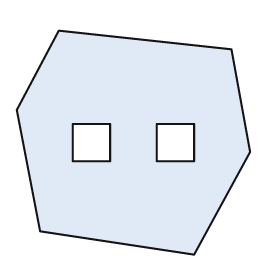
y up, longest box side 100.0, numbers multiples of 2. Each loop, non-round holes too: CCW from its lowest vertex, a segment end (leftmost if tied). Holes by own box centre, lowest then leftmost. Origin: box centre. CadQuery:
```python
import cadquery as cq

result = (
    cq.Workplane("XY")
    .moveTo(26.0, -48.0)
    .lineTo(50.0, -4.0)
    .lineTo(42.0, 40.0)
    .lineTo(-32.0, 48.0)
    .lineTo(-50.0, 14.0)
    .lineTo(-40.0, -38.0)
    .close()
    .moveTo(-26.0, -8.0)
    .lineTo(-10.0, -8.0)
    .lineTo(-10.0, 8.0)
    .lineTo(-26.0, 8.0)
    .close()
    .moveTo(10.0, -8.0)
    .lineTo(26.0, -8.0)
    .lineTo(26.0, 8.0)
    .lineTo(10.0, 8.0)
    .close()
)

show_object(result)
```